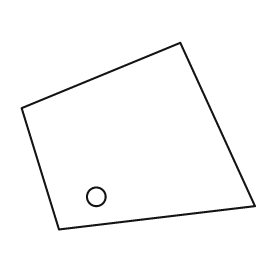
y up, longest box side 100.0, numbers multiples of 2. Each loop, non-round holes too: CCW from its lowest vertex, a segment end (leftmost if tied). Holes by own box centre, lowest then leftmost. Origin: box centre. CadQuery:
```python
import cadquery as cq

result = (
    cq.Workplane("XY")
    .moveTo(-34.0, -40.0)
    .lineTo(50.0, -30.0)
    .lineTo(18.0, 40.0)
    .lineTo(-50.0, 12.0)
    .close()
    .moveTo(-18.0, -26.0)
    .circle(4.0)
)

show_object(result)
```